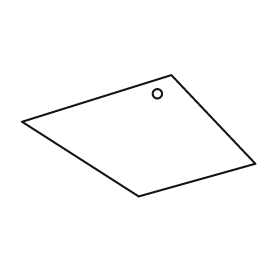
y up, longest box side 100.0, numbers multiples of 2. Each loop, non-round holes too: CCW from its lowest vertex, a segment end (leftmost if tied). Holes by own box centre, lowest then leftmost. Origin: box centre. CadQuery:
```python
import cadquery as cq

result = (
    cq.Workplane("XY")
    .moveTo(0.0, -26.0)
    .lineTo(50.0, -12.0)
    .lineTo(14.0, 26.0)
    .lineTo(-50.0, 6.0)
    .close()
    .moveTo(8.0, 18.0)
    .circle(2.0)
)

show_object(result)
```